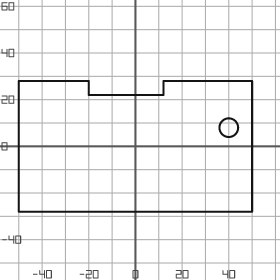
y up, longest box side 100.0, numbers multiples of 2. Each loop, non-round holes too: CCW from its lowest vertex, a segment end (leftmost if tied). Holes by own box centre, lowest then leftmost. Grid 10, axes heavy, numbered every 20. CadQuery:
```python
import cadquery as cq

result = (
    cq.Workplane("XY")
    .moveTo(-50.0, -28.0)
    .lineTo(50.0, -28.0)
    .lineTo(50.0, 28.0)
    .lineTo(12.0, 28.0)
    .lineTo(12.0, 22.0)
    .lineTo(-20.0, 22.0)
    .lineTo(-20.0, 28.0)
    .lineTo(-50.0, 28.0)
    .close()
    .moveTo(40.0, 8.0)
    .circle(4.0)
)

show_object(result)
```